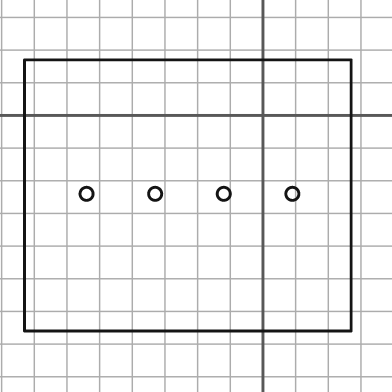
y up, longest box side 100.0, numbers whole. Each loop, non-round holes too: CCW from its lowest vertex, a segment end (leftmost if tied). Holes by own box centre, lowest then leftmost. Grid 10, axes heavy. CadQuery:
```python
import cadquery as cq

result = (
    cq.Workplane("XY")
    .moveTo(-73.0, -66.0)
    .lineTo(27.0, -66.0)
    .lineTo(27.0, 17.0)
    .lineTo(-73.0, 17.0)
    .close()
    .moveTo(-54.0, -24.0)
    .circle(2.0)
    .moveTo(-33.0, -24.0)
    .circle(2.0)
    .moveTo(-12.0, -24.0)
    .circle(2.0)
    .moveTo(9.0, -24.0)
    .circle(2.0)
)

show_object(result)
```